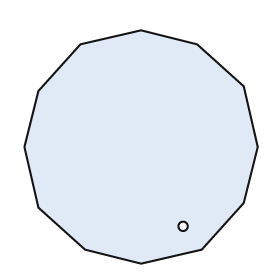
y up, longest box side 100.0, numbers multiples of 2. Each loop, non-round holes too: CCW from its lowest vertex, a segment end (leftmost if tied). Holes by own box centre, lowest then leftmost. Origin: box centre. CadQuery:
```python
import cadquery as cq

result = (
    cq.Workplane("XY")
    .moveTo(0.0, -50.0)
    .lineTo(26.0, -44.0)
    .lineTo(44.0, -24.0)
    .lineTo(50.0, 0.0)
    .lineTo(44.0, 26.0)
    .lineTo(24.0, 44.0)
    .lineTo(0.0, 50.0)
    .lineTo(-26.0, 44.0)
    .lineTo(-44.0, 24.0)
    .lineTo(-50.0, 0.0)
    .lineTo(-44.0, -26.0)
    .lineTo(-24.0, -44.0)
    .close()
    .moveTo(18.0, -34.0)
    .circle(2.0)
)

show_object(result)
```